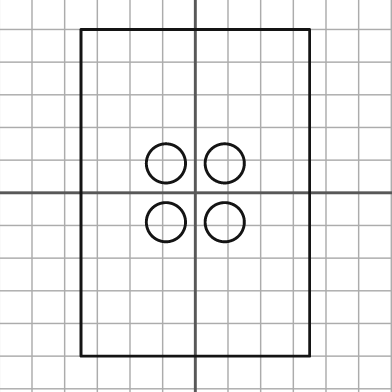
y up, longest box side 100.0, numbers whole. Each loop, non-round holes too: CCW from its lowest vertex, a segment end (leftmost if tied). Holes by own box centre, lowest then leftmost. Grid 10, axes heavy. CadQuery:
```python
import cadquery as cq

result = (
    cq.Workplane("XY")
    .moveTo(-35.0, -50.0)
    .lineTo(35.0, -50.0)
    .lineTo(35.0, 50.0)
    .lineTo(-35.0, 50.0)
    .close()
    .moveTo(-9.0, -9.0)
    .circle(6.0)
    .moveTo(9.0, -9.0)
    .circle(6.0)
    .moveTo(-9.0, 9.0)
    .circle(6.0)
    .moveTo(9.0, 9.0)
    .circle(6.0)
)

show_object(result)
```